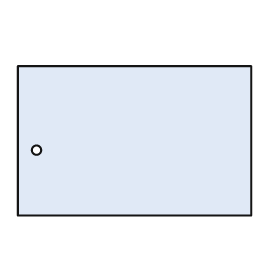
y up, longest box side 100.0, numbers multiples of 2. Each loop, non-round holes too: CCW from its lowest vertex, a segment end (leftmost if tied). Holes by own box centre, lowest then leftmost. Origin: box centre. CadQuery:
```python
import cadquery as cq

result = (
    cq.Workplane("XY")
    .moveTo(-50.0, -32.0)
    .lineTo(50.0, -32.0)
    .lineTo(50.0, 32.0)
    .lineTo(-50.0, 32.0)
    .close()
    .moveTo(-42.0, -4.0)
    .circle(2.0)
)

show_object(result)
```